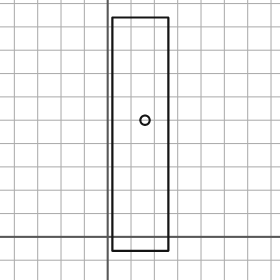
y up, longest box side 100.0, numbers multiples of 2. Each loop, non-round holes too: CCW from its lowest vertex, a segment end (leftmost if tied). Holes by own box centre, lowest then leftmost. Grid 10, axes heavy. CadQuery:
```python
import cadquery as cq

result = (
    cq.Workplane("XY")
    .moveTo(2.0, -6.0)
    .lineTo(26.0, -6.0)
    .lineTo(26.0, 94.0)
    .lineTo(2.0, 94.0)
    .close()
    .moveTo(16.0, 50.0)
    .circle(2.0)
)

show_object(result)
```